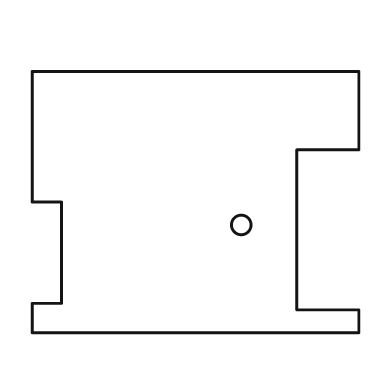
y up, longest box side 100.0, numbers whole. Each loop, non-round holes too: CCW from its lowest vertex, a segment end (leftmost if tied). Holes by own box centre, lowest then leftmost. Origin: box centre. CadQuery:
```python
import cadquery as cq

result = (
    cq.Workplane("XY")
    .moveTo(-50.0, -40.0)
    .lineTo(50.0, -40.0)
    .lineTo(50.0, -33.0)
    .lineTo(31.0, -33.0)
    .lineTo(31.0, 16.0)
    .lineTo(50.0, 16.0)
    .lineTo(50.0, 40.0)
    .lineTo(-50.0, 40.0)
    .lineTo(-50.0, 0.0)
    .lineTo(-41.0, 0.0)
    .lineTo(-41.0, -31.0)
    .lineTo(-50.0, -31.0)
    .close()
    .moveTo(14.0, -7.0)
    .circle(3.0)
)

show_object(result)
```